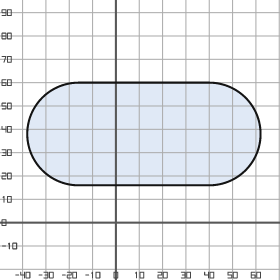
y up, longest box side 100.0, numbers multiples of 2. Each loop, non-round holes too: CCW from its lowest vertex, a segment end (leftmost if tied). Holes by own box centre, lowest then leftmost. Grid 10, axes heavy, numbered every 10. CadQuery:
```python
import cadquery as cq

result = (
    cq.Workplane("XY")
    .moveTo(-16.0, 16.0)
    .lineTo(40.0, 16.0)
    .threePointArc((62.0, 38.0), (40.0, 60.0))
    .lineTo(-16.0, 60.0)
    .threePointArc((-38.0, 38.0), (-16.0, 16.0))
    .close()
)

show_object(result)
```